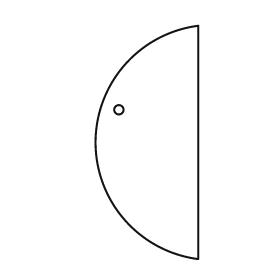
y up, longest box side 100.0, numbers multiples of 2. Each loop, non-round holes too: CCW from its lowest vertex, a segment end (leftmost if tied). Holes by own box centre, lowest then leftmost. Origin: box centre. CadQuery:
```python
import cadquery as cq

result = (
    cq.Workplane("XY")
    .moveTo(22.0, -50.0)
    .lineTo(22.0, 50.0)
    .threePointArc((-22.0, 0.0), (22.0, -50.0))
    .close()
    .moveTo(-12.0, 14.0)
    .circle(2.0)
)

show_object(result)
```